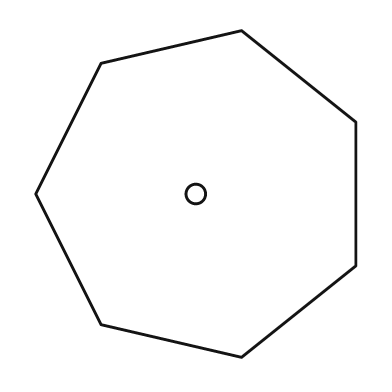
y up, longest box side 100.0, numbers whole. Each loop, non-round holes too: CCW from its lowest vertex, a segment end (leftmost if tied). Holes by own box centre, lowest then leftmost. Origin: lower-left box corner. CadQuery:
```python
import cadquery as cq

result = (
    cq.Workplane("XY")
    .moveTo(63.0, 0.0)
    .lineTo(98.0, 28.0)
    .lineTo(98.0, 72.0)
    .lineTo(63.0, 100.0)
    .lineTo(20.0, 90.0)
    .lineTo(0.0, 50.0)
    .lineTo(20.0, 10.0)
    .close()
    .moveTo(49.0, 50.0)
    .circle(3.0)
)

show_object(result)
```